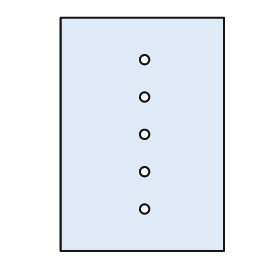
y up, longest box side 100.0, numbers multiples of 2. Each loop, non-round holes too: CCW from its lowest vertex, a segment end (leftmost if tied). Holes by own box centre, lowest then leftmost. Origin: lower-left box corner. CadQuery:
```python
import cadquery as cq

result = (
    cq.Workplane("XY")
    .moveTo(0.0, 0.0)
    .lineTo(70.0, 0.0)
    .lineTo(70.0, 100.0)
    .lineTo(0.0, 100.0)
    .close()
    .moveTo(36.0, 18.0)
    .circle(2.0)
    .moveTo(36.0, 34.0)
    .circle(2.0)
    .moveTo(36.0, 50.0)
    .circle(2.0)
    .moveTo(36.0, 66.0)
    .circle(2.0)
    .moveTo(36.0, 82.0)
    .circle(2.0)
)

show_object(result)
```